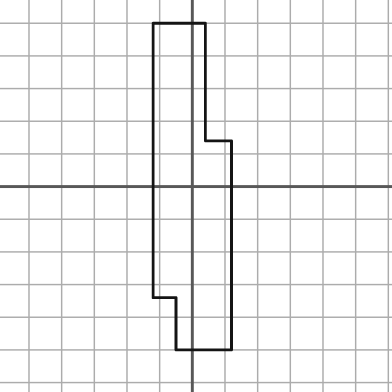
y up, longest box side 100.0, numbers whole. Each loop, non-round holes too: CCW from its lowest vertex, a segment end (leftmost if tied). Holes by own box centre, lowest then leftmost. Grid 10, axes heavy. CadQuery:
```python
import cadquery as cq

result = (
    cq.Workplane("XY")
    .moveTo(-5.0, -50.0)
    .lineTo(12.0, -50.0)
    .lineTo(12.0, 14.0)
    .lineTo(4.0, 14.0)
    .lineTo(4.0, 50.0)
    .lineTo(-12.0, 50.0)
    .lineTo(-12.0, -34.0)
    .lineTo(-5.0, -34.0)
    .close()
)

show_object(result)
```